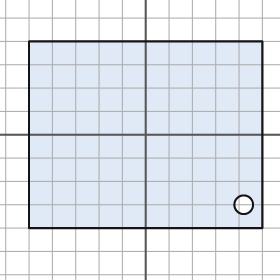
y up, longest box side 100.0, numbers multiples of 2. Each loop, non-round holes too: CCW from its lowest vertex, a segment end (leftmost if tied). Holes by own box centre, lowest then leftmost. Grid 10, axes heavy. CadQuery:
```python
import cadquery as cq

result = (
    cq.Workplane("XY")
    .moveTo(-50.0, -40.0)
    .lineTo(50.0, -40.0)
    .lineTo(50.0, 40.0)
    .lineTo(-50.0, 40.0)
    .close()
    .moveTo(42.0, -30.0)
    .circle(4.0)
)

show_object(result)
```